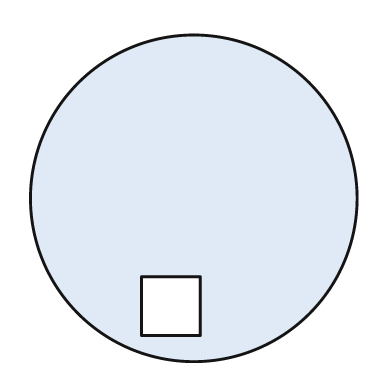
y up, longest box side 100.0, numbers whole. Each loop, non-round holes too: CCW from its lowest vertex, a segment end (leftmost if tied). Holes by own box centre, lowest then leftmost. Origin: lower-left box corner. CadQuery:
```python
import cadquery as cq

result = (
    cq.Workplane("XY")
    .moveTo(50.0, 50.0)
    .circle(50.0)
    .moveTo(34.0, 8.0)
    .lineTo(52.0, 8.0)
    .lineTo(52.0, 26.0)
    .lineTo(34.0, 26.0)
    .close()
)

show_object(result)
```